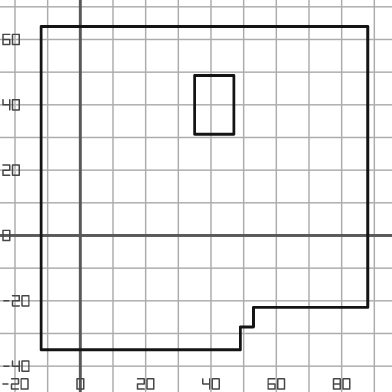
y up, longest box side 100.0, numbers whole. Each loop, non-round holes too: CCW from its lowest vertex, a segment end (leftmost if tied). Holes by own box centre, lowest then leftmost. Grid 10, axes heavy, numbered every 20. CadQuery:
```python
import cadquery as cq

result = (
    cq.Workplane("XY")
    .moveTo(-12.0, -35.0)
    .lineTo(49.0, -35.0)
    .lineTo(49.0, -28.0)
    .lineTo(53.0, -28.0)
    .lineTo(53.0, -22.0)
    .lineTo(88.0, -22.0)
    .lineTo(88.0, 64.0)
    .lineTo(-12.0, 64.0)
    .close()
    .moveTo(35.0, 31.0)
    .lineTo(47.0, 31.0)
    .lineTo(47.0, 49.0)
    .lineTo(35.0, 49.0)
    .close()
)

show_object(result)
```